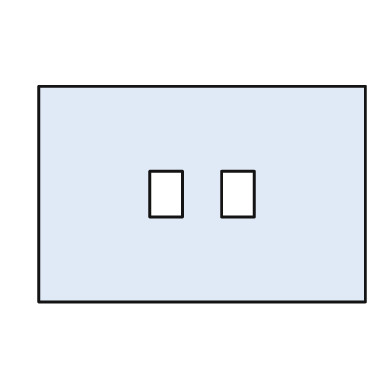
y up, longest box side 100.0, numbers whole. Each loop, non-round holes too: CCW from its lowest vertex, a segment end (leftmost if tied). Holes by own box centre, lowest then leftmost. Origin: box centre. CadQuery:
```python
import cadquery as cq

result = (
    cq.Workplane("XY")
    .moveTo(-50.0, -33.0)
    .lineTo(50.0, -33.0)
    .lineTo(50.0, 33.0)
    .lineTo(-50.0, 33.0)
    .close()
    .moveTo(-16.0, -7.0)
    .lineTo(-6.0, -7.0)
    .lineTo(-6.0, 7.0)
    .lineTo(-16.0, 7.0)
    .close()
    .moveTo(6.0, -7.0)
    .lineTo(16.0, -7.0)
    .lineTo(16.0, 7.0)
    .lineTo(6.0, 7.0)
    .close()
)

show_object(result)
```